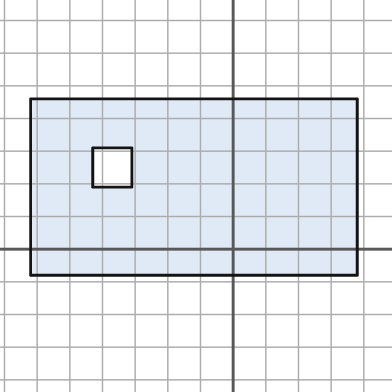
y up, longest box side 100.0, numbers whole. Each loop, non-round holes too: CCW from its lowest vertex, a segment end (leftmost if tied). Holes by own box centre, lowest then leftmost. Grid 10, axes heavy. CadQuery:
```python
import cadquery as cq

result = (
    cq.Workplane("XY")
    .moveTo(-62.0, -8.0)
    .lineTo(38.0, -8.0)
    .lineTo(38.0, 46.0)
    .lineTo(-62.0, 46.0)
    .close()
    .moveTo(-43.0, 19.0)
    .lineTo(-31.0, 19.0)
    .lineTo(-31.0, 31.0)
    .lineTo(-43.0, 31.0)
    .close()
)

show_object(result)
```